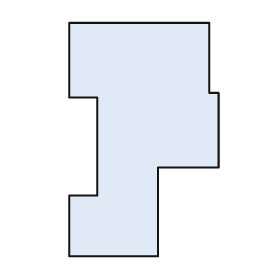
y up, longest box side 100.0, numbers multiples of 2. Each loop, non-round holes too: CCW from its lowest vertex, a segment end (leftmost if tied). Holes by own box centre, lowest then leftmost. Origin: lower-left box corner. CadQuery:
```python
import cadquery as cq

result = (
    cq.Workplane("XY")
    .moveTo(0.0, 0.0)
    .lineTo(38.0, 0.0)
    .lineTo(38.0, 38.0)
    .lineTo(64.0, 38.0)
    .lineTo(64.0, 70.0)
    .lineTo(60.0, 70.0)
    .lineTo(60.0, 100.0)
    .lineTo(0.0, 100.0)
    .lineTo(0.0, 68.0)
    .lineTo(12.0, 68.0)
    .lineTo(12.0, 26.0)
    .lineTo(0.0, 26.0)
    .close()
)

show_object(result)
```